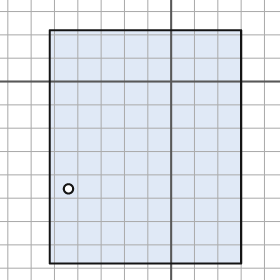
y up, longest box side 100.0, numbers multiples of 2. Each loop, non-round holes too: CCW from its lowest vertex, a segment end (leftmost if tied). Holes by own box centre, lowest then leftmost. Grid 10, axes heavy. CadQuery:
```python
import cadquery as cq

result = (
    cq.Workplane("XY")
    .moveTo(-52.0, -78.0)
    .lineTo(30.0, -78.0)
    .lineTo(30.0, 22.0)
    .lineTo(-52.0, 22.0)
    .close()
    .moveTo(-44.0, -46.0)
    .circle(2.0)
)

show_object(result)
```